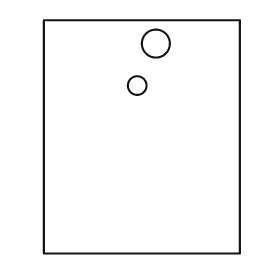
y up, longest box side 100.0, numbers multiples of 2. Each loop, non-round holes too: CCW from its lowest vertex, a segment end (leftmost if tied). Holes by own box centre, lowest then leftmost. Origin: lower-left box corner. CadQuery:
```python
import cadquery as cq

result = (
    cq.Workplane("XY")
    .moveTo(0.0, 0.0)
    .lineTo(84.0, 0.0)
    .lineTo(84.0, 100.0)
    .lineTo(0.0, 100.0)
    .close()
    .moveTo(40.0, 72.0)
    .circle(4.0)
    .moveTo(48.0, 90.0)
    .circle(6.0)
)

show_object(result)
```